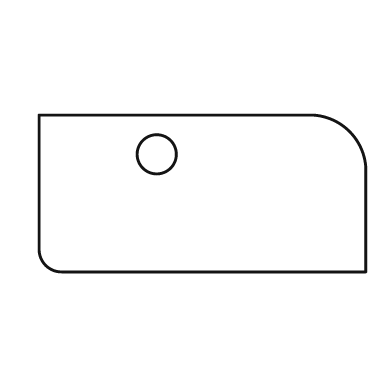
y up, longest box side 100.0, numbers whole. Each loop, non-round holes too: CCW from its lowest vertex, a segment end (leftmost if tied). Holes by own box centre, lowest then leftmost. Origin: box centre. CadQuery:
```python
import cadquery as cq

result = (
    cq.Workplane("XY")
    .moveTo(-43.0, -24.0)
    .lineTo(50.0, -24.0)
    .lineTo(50.0, 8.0)
    .threePointArc((45.0, 19.0), (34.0, 24.0))
    .lineTo(-50.0, 24.0)
    .lineTo(-50.0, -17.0)
    .threePointArc((-48.0, -22.0), (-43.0, -24.0))
    .close()
    .moveTo(-14.0, 12.0)
    .circle(6.0)
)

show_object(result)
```